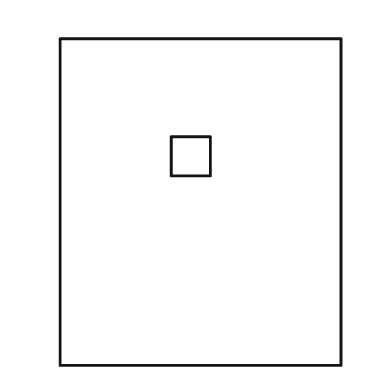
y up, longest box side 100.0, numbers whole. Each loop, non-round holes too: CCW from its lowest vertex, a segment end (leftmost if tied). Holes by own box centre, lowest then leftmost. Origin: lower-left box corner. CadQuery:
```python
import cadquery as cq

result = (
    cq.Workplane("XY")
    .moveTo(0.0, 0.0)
    .lineTo(86.0, 0.0)
    .lineTo(86.0, 100.0)
    .lineTo(0.0, 100.0)
    .close()
    .moveTo(34.0, 58.0)
    .lineTo(46.0, 58.0)
    .lineTo(46.0, 70.0)
    .lineTo(34.0, 70.0)
    .close()
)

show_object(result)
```